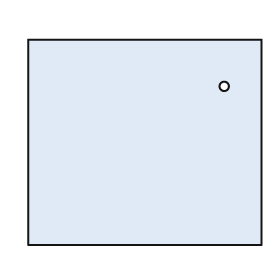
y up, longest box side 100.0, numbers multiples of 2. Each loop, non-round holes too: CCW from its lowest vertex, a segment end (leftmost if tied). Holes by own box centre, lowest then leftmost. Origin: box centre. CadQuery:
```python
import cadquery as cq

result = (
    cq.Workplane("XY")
    .moveTo(-50.0, -44.0)
    .lineTo(50.0, -44.0)
    .lineTo(50.0, 44.0)
    .lineTo(-50.0, 44.0)
    .close()
    .moveTo(34.0, 24.0)
    .circle(2.0)
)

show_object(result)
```